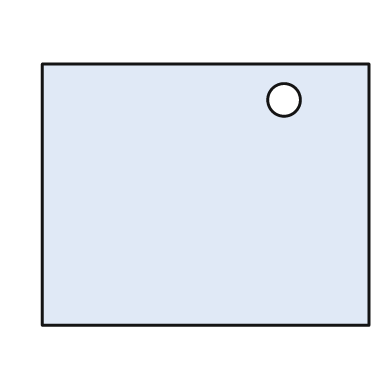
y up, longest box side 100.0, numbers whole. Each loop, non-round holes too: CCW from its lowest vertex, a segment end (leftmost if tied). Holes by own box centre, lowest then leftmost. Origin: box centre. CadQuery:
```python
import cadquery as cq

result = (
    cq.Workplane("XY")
    .moveTo(-50.0, -40.0)
    .lineTo(50.0, -40.0)
    .lineTo(50.0, 40.0)
    .lineTo(-50.0, 40.0)
    .close()
    .moveTo(24.0, 29.0)
    .circle(5.0)
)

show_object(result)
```